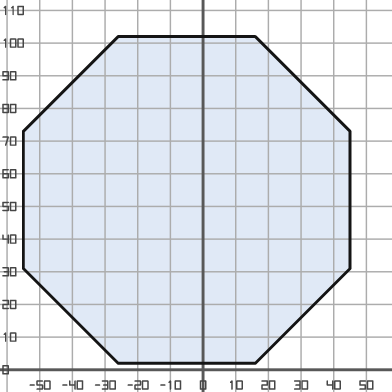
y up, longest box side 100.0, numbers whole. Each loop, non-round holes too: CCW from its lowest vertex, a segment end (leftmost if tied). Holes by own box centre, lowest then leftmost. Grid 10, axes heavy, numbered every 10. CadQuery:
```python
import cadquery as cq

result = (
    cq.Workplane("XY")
    .moveTo(-26.0, 2.0)
    .lineTo(16.0, 2.0)
    .lineTo(45.0, 31.0)
    .lineTo(45.0, 73.0)
    .lineTo(16.0, 102.0)
    .lineTo(-26.0, 102.0)
    .lineTo(-55.0, 73.0)
    .lineTo(-55.0, 31.0)
    .close()
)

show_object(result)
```